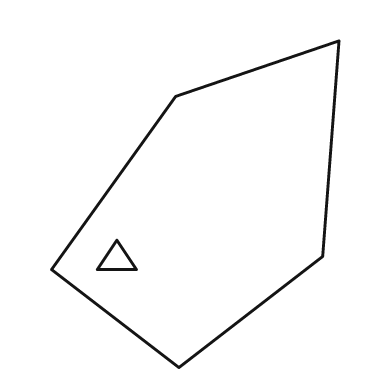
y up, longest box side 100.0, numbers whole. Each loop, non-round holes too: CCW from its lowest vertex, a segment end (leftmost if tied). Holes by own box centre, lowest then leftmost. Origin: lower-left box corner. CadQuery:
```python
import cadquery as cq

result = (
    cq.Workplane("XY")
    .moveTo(39.0, 0.0)
    .lineTo(83.0, 34.0)
    .lineTo(88.0, 100.0)
    .lineTo(38.0, 83.0)
    .lineTo(0.0, 30.0)
    .close()
    .moveTo(14.0, 30.0)
    .lineTo(26.0, 30.0)
    .lineTo(20.0, 39.0)
    .close()
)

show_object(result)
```